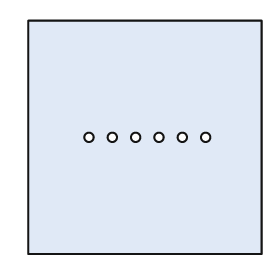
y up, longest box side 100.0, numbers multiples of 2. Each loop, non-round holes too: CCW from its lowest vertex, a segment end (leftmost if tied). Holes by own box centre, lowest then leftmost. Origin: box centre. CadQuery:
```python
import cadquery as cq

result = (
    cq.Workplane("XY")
    .moveTo(-50.0, -50.0)
    .lineTo(50.0, -50.0)
    .lineTo(50.0, 50.0)
    .lineTo(-50.0, 50.0)
    .close()
    .moveTo(-24.0, 0.0)
    .circle(2.0)
    .moveTo(-14.0, 0.0)
    .circle(2.0)
    .moveTo(-4.0, 0.0)
    .circle(2.0)
    .moveTo(6.0, 0.0)
    .circle(2.0)
    .moveTo(16.0, 0.0)
    .circle(2.0)
    .moveTo(26.0, 0.0)
    .circle(2.0)
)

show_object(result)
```